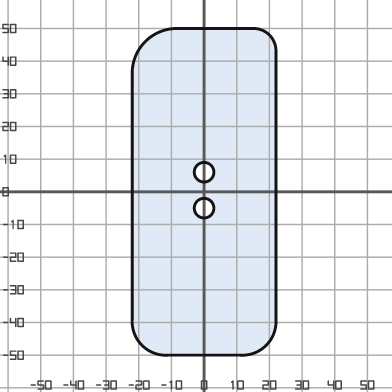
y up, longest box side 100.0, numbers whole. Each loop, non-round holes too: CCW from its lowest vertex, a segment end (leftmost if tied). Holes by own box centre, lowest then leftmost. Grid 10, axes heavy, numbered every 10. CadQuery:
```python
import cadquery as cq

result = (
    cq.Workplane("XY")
    .moveTo(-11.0, -50.0)
    .lineTo(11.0, -50.0)
    .threePointArc((19.0, -47.0), (22.0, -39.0))
    .lineTo(22.0, 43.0)
    .threePointArc((20.0, 48.0), (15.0, 50.0))
    .lineTo(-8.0, 50.0)
    .threePointArc((-18.0, 46.0), (-22.0, 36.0))
    .lineTo(-22.0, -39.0)
    .threePointArc((-19.0, -47.0), (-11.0, -50.0))
    .close()
    .moveTo(0.0, -5.0)
    .circle(3.0)
    .moveTo(0.0, 6.0)
    .circle(3.0)
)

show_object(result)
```